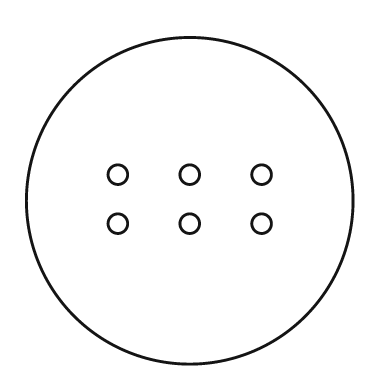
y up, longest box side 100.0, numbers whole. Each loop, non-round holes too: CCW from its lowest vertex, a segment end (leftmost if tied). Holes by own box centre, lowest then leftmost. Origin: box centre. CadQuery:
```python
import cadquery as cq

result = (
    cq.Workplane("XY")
    .moveTo(0.0, 0.0)
    .circle(50.0)
    .moveTo(-22.0, -7.0)
    .circle(3.0)
    .moveTo(0.0, -7.0)
    .circle(3.0)
    .moveTo(22.0, -7.0)
    .circle(3.0)
    .moveTo(-22.0, 8.0)
    .circle(3.0)
    .moveTo(0.0, 8.0)
    .circle(3.0)
    .moveTo(22.0, 8.0)
    .circle(3.0)
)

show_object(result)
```